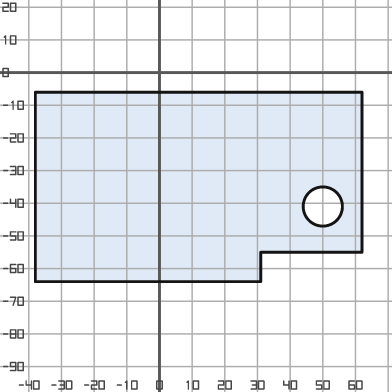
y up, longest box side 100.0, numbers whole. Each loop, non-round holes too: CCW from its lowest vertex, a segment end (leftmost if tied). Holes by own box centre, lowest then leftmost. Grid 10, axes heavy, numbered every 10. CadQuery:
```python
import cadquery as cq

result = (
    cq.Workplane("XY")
    .moveTo(-38.0, -64.0)
    .lineTo(31.0, -64.0)
    .lineTo(31.0, -55.0)
    .lineTo(62.0, -55.0)
    .lineTo(62.0, -6.0)
    .lineTo(-38.0, -6.0)
    .close()
    .moveTo(50.0, -41.0)
    .circle(6.0)
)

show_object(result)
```